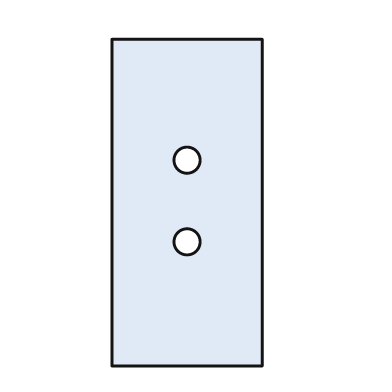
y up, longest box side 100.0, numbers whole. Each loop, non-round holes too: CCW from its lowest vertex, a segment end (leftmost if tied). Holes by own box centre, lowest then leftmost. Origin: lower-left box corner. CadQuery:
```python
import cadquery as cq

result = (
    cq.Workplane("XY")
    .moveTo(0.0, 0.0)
    .lineTo(46.0, 0.0)
    .lineTo(46.0, 100.0)
    .lineTo(0.0, 100.0)
    .close()
    .moveTo(23.0, 38.0)
    .circle(4.0)
    .moveTo(23.0, 63.0)
    .circle(4.0)
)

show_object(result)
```